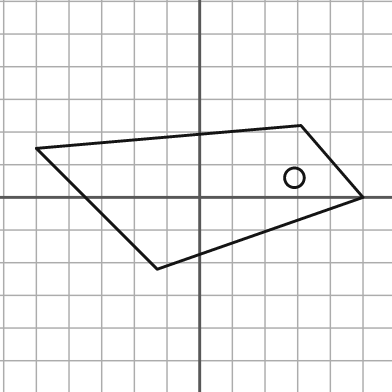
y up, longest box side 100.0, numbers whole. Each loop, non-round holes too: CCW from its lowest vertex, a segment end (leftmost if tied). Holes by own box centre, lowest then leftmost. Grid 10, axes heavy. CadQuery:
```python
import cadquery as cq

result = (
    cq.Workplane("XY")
    .moveTo(-13.0, -22.0)
    .lineTo(50.0, 0.0)
    .lineTo(31.0, 22.0)
    .lineTo(-50.0, 15.0)
    .close()
    .moveTo(29.0, 6.0)
    .circle(3.0)
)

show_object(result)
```